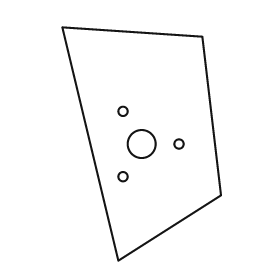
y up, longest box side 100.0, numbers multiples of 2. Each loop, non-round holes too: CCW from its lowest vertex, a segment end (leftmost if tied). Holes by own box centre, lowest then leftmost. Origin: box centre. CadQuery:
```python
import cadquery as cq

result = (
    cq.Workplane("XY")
    .moveTo(-10.0, -50.0)
    .lineTo(34.0, -22.0)
    .lineTo(26.0, 46.0)
    .lineTo(-34.0, 50.0)
    .close()
    .moveTo(-8.0, -14.0)
    .circle(2.0)
    .moveTo(0.0, 0.0)
    .circle(6.0)
    .moveTo(16.0, 0.0)
    .circle(2.0)
    .moveTo(-8.0, 14.0)
    .circle(2.0)
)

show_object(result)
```